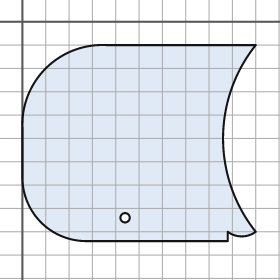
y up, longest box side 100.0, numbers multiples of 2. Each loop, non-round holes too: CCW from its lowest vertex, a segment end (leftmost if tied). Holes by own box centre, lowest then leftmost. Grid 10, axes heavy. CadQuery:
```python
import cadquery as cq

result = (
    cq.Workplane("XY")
    .moveTo(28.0, -94.0)
    .lineTo(88.0, -94.0)
    .lineTo(88.0, -90.0)
    .threePointArc((94.0, -92.0), (100.0, -90.0))
    .threePointArc((86.0, -50.0), (100.0, -10.0))
    .lineTo(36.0, -10.0)
    .threePointArc((10.0, -20.0), (0.0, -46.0))
    .lineTo(0.0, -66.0)
    .threePointArc((8.0, -86.0), (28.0, -94.0))
    .close()
    .moveTo(44.0, -84.0)
    .circle(2.0)
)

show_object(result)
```